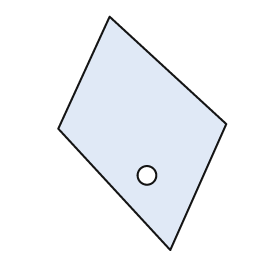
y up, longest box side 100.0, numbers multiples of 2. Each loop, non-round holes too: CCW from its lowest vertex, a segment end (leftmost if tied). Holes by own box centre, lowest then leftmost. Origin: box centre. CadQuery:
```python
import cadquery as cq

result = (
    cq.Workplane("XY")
    .moveTo(12.0, -50.0)
    .lineTo(36.0, 4.0)
    .lineTo(-14.0, 50.0)
    .lineTo(-36.0, 2.0)
    .close()
    .moveTo(2.0, -18.0)
    .circle(4.0)
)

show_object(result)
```